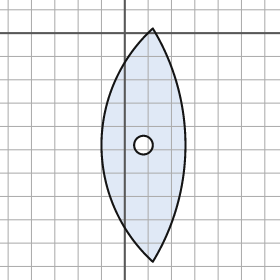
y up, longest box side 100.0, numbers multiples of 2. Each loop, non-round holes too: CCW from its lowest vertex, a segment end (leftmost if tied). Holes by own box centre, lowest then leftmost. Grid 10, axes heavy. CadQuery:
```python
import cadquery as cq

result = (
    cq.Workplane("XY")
    .moveTo(12.0, -98.0)
    .threePointArc((26.0, -48.0), (12.0, 2.0))
    .threePointArc((-10.0, -48.0), (12.0, -98.0))
    .close()
    .moveTo(8.0, -48.0)
    .circle(4.0)
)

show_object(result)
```